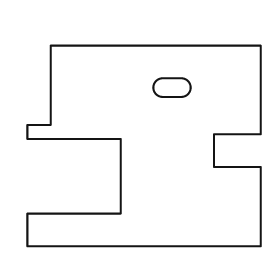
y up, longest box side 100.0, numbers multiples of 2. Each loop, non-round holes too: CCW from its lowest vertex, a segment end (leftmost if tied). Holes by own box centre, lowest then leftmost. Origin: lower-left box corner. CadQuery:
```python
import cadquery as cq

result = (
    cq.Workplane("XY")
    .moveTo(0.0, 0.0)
    .lineTo(100.0, 0.0)
    .lineTo(100.0, 34.0)
    .lineTo(80.0, 34.0)
    .lineTo(80.0, 48.0)
    .lineTo(100.0, 48.0)
    .lineTo(100.0, 86.0)
    .lineTo(10.0, 86.0)
    .lineTo(10.0, 52.0)
    .lineTo(0.0, 52.0)
    .lineTo(0.0, 46.0)
    .lineTo(40.0, 46.0)
    .lineTo(40.0, 14.0)
    .lineTo(0.0, 14.0)
    .close()
    .moveTo(58.0, 64.0)
    .lineTo(66.0, 64.0)
    .threePointArc((70.0, 68.0), (66.0, 72.0))
    .lineTo(58.0, 72.0)
    .threePointArc((54.0, 68.0), (58.0, 64.0))
    .close()
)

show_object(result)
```